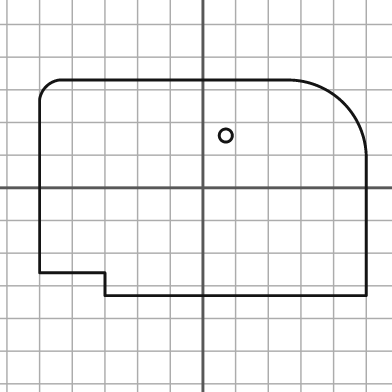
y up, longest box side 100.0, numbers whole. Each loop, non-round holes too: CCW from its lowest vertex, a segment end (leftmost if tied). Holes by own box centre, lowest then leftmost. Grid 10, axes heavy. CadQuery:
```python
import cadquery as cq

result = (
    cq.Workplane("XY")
    .moveTo(-30.0, -33.0)
    .lineTo(50.0, -33.0)
    .lineTo(50.0, 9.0)
    .threePointArc((43.0, 26.0), (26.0, 33.0))
    .lineTo(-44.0, 33.0)
    .threePointArc((-48.0, 31.0), (-50.0, 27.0))
    .lineTo(-50.0, -26.0)
    .lineTo(-30.0, -26.0)
    .close()
    .moveTo(7.0, 16.0)
    .circle(2.0)
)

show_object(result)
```